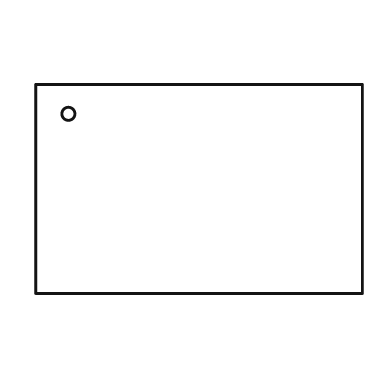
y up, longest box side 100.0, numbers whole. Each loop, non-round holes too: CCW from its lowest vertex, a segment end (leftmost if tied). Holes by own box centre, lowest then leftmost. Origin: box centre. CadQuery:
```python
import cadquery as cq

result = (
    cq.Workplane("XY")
    .moveTo(-50.0, -32.0)
    .lineTo(50.0, -32.0)
    .lineTo(50.0, 32.0)
    .lineTo(-50.0, 32.0)
    .close()
    .moveTo(-40.0, 23.0)
    .circle(2.0)
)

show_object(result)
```